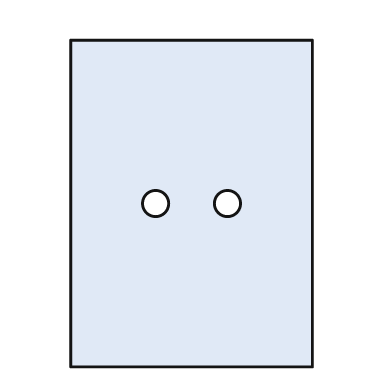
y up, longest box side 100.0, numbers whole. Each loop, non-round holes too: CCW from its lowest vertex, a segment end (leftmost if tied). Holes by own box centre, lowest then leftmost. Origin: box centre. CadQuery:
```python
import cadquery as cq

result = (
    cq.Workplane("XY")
    .moveTo(-37.0, -50.0)
    .lineTo(37.0, -50.0)
    .lineTo(37.0, 50.0)
    .lineTo(-37.0, 50.0)
    .close()
    .moveTo(-11.0, 0.0)
    .circle(4.0)
    .moveTo(11.0, 0.0)
    .circle(4.0)
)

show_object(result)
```